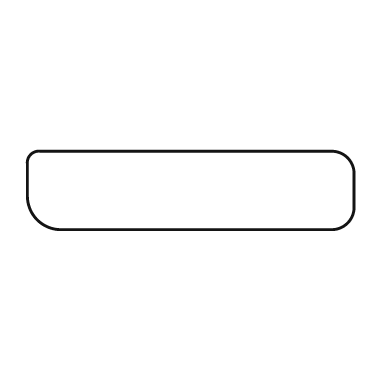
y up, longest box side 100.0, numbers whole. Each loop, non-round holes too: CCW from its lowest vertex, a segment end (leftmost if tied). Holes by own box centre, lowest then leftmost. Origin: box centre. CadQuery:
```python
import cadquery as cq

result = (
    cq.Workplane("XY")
    .moveTo(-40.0, -12.0)
    .lineTo(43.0, -12.0)
    .threePointArc((48.0, -10.0), (50.0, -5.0))
    .lineTo(50.0, 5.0)
    .threePointArc((48.0, 10.0), (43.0, 12.0))
    .lineTo(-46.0, 12.0)
    .threePointArc((-49.0, 11.0), (-50.0, 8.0))
    .lineTo(-50.0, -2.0)
    .threePointArc((-47.0, -9.0), (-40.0, -12.0))
    .close()
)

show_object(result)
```